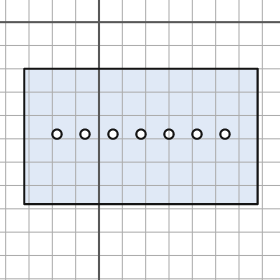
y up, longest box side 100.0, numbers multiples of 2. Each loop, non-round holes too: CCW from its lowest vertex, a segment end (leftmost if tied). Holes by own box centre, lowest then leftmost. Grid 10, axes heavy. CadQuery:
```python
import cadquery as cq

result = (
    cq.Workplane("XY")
    .moveTo(-32.0, -78.0)
    .lineTo(68.0, -78.0)
    .lineTo(68.0, -20.0)
    .lineTo(-32.0, -20.0)
    .close()
    .moveTo(-18.0, -48.0)
    .circle(2.0)
    .moveTo(-6.0, -48.0)
    .circle(2.0)
    .moveTo(6.0, -48.0)
    .circle(2.0)
    .moveTo(18.0, -48.0)
    .circle(2.0)
    .moveTo(30.0, -48.0)
    .circle(2.0)
    .moveTo(42.0, -48.0)
    .circle(2.0)
    .moveTo(54.0, -48.0)
    .circle(2.0)
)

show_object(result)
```